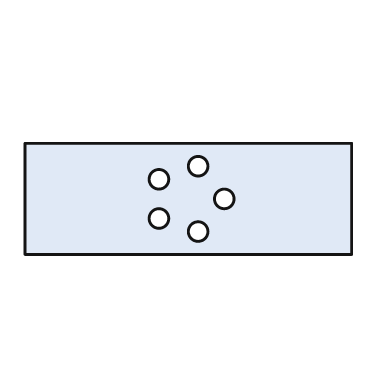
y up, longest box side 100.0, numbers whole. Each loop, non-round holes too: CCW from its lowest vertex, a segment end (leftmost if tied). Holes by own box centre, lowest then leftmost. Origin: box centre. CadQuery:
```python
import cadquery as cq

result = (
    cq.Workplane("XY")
    .moveTo(-50.0, -17.0)
    .lineTo(50.0, -17.0)
    .lineTo(50.0, 17.0)
    .lineTo(-50.0, 17.0)
    .close()
    .moveTo(3.0, -10.0)
    .circle(3.0)
    .moveTo(-9.0, -6.0)
    .circle(3.0)
    .moveTo(11.0, 0.0)
    .circle(3.0)
    .moveTo(-9.0, 6.0)
    .circle(3.0)
    .moveTo(3.0, 10.0)
    .circle(3.0)
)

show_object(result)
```